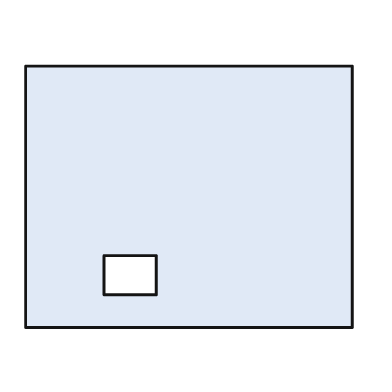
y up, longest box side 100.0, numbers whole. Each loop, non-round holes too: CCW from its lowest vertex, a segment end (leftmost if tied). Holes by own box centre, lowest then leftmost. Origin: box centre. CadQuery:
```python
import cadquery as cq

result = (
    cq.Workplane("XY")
    .moveTo(-50.0, -40.0)
    .lineTo(50.0, -40.0)
    .lineTo(50.0, 40.0)
    .lineTo(-50.0, 40.0)
    .close()
    .moveTo(-26.0, -30.0)
    .lineTo(-10.0, -30.0)
    .lineTo(-10.0, -18.0)
    .lineTo(-26.0, -18.0)
    .close()
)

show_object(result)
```